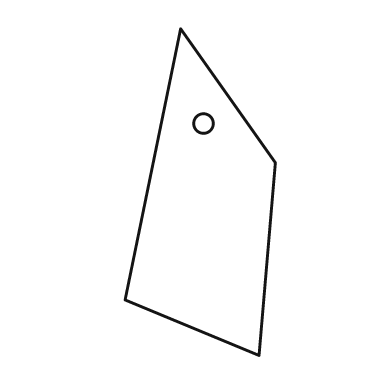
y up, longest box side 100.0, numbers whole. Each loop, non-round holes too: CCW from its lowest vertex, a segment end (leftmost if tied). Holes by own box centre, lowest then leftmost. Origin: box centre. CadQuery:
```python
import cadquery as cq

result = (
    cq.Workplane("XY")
    .moveTo(18.0, -50.0)
    .lineTo(23.0, 9.0)
    .lineTo(-6.0, 50.0)
    .lineTo(-23.0, -33.0)
    .close()
    .moveTo(1.0, 21.0)
    .circle(3.0)
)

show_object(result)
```